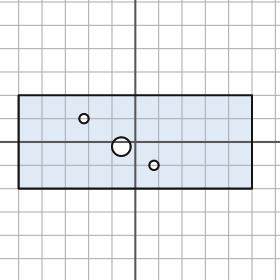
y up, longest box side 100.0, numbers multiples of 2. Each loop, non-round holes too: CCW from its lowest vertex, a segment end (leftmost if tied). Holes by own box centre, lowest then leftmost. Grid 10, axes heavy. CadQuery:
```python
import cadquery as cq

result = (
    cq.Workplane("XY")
    .moveTo(-50.0, -20.0)
    .lineTo(50.0, -20.0)
    .lineTo(50.0, 20.0)
    .lineTo(-50.0, 20.0)
    .close()
    .moveTo(8.0, -10.0)
    .circle(2.0)
    .moveTo(-6.0, -2.0)
    .circle(4.0)
    .moveTo(-22.0, 10.0)
    .circle(2.0)
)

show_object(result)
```